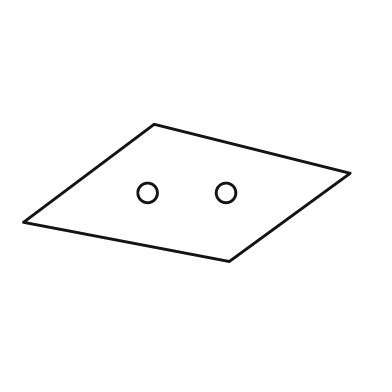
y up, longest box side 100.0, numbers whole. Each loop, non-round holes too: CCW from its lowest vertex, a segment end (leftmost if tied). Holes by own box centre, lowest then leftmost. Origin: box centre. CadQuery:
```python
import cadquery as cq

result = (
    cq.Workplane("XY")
    .moveTo(13.0, -21.0)
    .lineTo(50.0, 6.0)
    .lineTo(-10.0, 21.0)
    .lineTo(-50.0, -9.0)
    .close()
    .moveTo(-12.0, 0.0)
    .circle(3.0)
    .moveTo(12.0, 0.0)
    .circle(3.0)
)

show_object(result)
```